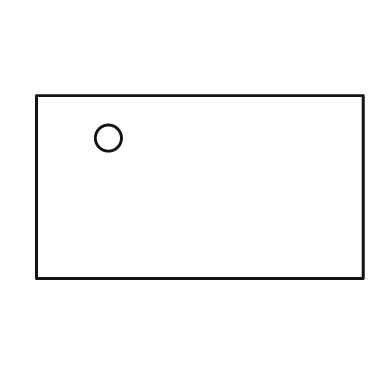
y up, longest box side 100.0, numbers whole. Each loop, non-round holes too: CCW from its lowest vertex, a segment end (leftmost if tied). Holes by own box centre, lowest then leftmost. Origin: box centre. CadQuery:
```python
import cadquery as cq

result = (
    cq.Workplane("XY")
    .moveTo(-50.0, -28.0)
    .lineTo(50.0, -28.0)
    .lineTo(50.0, 28.0)
    .lineTo(-50.0, 28.0)
    .close()
    .moveTo(-28.0, 15.0)
    .circle(4.0)
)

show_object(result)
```